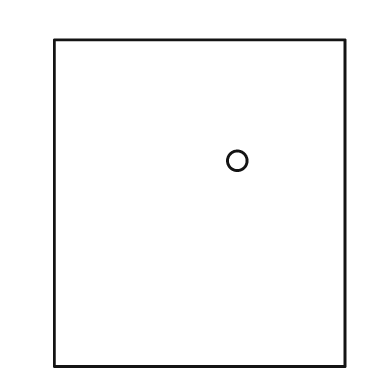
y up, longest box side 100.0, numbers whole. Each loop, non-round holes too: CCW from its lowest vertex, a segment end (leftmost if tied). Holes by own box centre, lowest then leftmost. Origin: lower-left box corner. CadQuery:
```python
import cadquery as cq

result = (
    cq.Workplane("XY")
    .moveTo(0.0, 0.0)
    .lineTo(89.0, 0.0)
    .lineTo(89.0, 100.0)
    .lineTo(0.0, 100.0)
    .close()
    .moveTo(56.0, 63.0)
    .circle(3.0)
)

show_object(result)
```